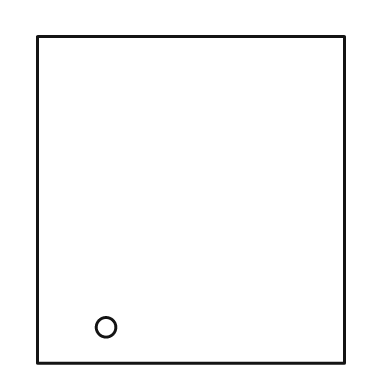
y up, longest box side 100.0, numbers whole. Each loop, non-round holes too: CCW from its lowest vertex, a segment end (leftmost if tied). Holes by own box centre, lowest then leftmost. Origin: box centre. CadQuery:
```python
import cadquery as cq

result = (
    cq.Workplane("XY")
    .moveTo(-47.0, -50.0)
    .lineTo(47.0, -50.0)
    .lineTo(47.0, 50.0)
    .lineTo(-47.0, 50.0)
    .close()
    .moveTo(-26.0, -39.0)
    .circle(3.0)
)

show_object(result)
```